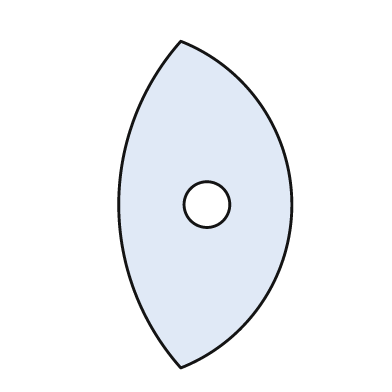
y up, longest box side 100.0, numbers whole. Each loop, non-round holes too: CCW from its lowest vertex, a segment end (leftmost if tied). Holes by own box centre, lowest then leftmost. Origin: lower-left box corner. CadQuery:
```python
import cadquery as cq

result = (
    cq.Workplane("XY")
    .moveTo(19.0, 0.0)
    .threePointArc((53.0, 50.0), (19.0, 100.0))
    .threePointArc((0.0, 50.0), (19.0, 0.0))
    .close()
    .moveTo(27.0, 50.0)
    .circle(7.0)
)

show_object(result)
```